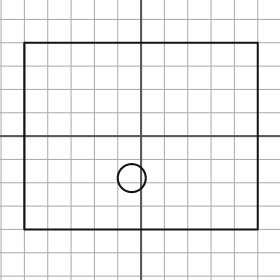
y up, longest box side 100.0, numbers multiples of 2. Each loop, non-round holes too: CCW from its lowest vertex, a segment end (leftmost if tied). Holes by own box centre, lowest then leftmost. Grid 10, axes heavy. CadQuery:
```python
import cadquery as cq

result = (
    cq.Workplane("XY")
    .moveTo(-50.0, -40.0)
    .lineTo(50.0, -40.0)
    .lineTo(50.0, 40.0)
    .lineTo(-50.0, 40.0)
    .close()
    .moveTo(-4.0, -18.0)
    .circle(6.0)
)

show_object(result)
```